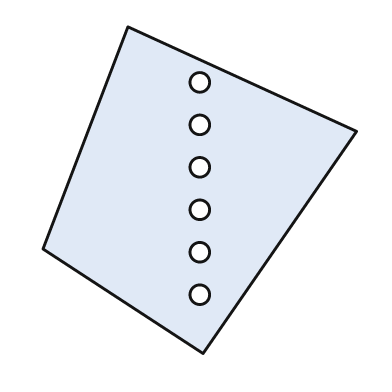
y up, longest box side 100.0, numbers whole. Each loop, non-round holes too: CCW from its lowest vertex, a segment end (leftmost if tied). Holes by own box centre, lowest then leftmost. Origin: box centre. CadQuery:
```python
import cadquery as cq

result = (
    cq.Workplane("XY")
    .moveTo(1.0, -50.0)
    .lineTo(48.0, 18.0)
    .lineTo(-22.0, 50.0)
    .lineTo(-48.0, -18.0)
    .close()
    .moveTo(0.0, -32.0)
    .circle(3.0)
    .moveTo(0.0, -19.0)
    .circle(3.0)
    .moveTo(0.0, -6.0)
    .circle(3.0)
    .moveTo(0.0, 7.0)
    .circle(3.0)
    .moveTo(0.0, 20.0)
    .circle(3.0)
    .moveTo(0.0, 33.0)
    .circle(3.0)
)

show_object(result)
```